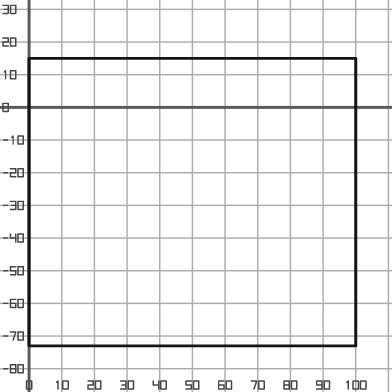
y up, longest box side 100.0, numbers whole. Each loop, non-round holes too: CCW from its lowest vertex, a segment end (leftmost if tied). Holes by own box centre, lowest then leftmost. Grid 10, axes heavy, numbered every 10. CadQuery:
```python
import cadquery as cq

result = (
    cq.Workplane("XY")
    .moveTo(0.0, -73.0)
    .lineTo(100.0, -73.0)
    .lineTo(100.0, 15.0)
    .lineTo(0.0, 15.0)
    .close()
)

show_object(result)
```